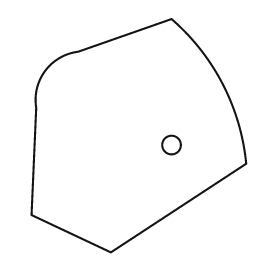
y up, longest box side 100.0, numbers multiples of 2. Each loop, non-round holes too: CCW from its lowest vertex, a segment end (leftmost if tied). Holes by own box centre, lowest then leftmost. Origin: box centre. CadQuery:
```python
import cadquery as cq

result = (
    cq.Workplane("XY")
    .moveTo(-12.0, -50.0)
    .lineTo(46.0, -12.0)
    .threePointArc((36.0, 22.0), (14.0, 50.0))
    .lineTo(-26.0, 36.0)
    .threePointArc((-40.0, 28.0), (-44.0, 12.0))
    .lineTo(-46.0, -34.0)
    .close()
    .moveTo(14.0, -4.0)
    .circle(4.0)
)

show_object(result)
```